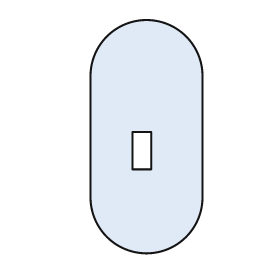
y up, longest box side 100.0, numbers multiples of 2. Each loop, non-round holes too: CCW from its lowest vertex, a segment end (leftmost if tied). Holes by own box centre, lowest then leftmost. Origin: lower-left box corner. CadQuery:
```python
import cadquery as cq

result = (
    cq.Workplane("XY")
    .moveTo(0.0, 24.0)
    .threePointArc((24.0, 0.0), (48.0, 24.0))
    .lineTo(48.0, 76.0)
    .threePointArc((24.0, 100.0), (0.0, 76.0))
    .close()
    .moveTo(18.0, 36.0)
    .lineTo(26.0, 36.0)
    .lineTo(26.0, 52.0)
    .lineTo(18.0, 52.0)
    .close()
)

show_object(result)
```